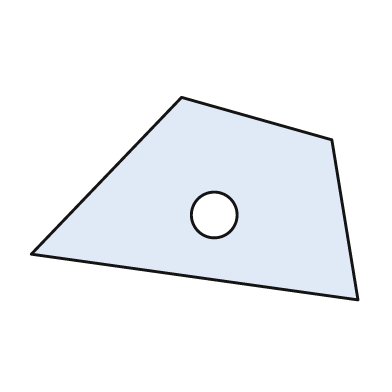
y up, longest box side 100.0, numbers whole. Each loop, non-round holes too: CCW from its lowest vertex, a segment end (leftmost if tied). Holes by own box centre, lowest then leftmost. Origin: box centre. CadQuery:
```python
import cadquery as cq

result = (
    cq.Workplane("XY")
    .moveTo(50.0, -31.0)
    .lineTo(42.0, 18.0)
    .lineTo(-4.0, 31.0)
    .lineTo(-50.0, -17.0)
    .close()
    .moveTo(6.0, -5.0)
    .circle(7.0)
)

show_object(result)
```